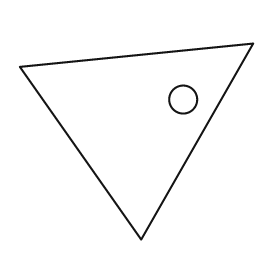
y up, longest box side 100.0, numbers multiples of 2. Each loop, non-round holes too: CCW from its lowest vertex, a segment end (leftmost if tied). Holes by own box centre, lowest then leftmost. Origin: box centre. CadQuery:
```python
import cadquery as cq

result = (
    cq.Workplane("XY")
    .moveTo(2.0, -42.0)
    .lineTo(50.0, 42.0)
    .lineTo(-50.0, 32.0)
    .close()
    .moveTo(20.0, 18.0)
    .circle(6.0)
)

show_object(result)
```